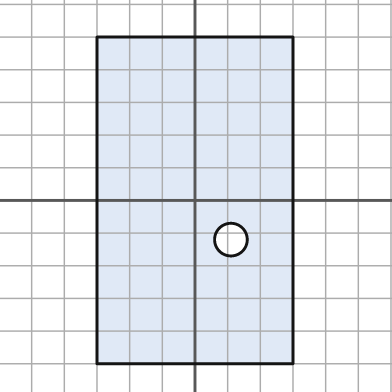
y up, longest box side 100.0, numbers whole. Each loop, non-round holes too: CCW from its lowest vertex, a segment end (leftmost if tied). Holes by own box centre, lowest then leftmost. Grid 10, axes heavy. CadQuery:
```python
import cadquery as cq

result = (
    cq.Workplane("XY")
    .moveTo(-30.0, -50.0)
    .lineTo(30.0, -50.0)
    .lineTo(30.0, 50.0)
    .lineTo(-30.0, 50.0)
    .close()
    .moveTo(11.0, -12.0)
    .circle(5.0)
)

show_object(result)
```